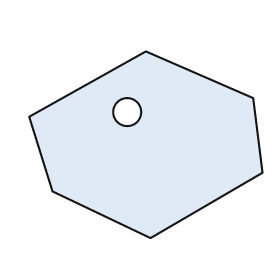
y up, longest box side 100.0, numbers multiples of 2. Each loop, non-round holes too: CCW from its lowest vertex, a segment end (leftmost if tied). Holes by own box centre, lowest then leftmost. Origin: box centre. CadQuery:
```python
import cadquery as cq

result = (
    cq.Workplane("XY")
    .moveTo(2.0, -40.0)
    .lineTo(50.0, -12.0)
    .lineTo(46.0, 20.0)
    .lineTo(0.0, 40.0)
    .lineTo(-50.0, 12.0)
    .lineTo(-40.0, -20.0)
    .close()
    .moveTo(-8.0, 14.0)
    .circle(6.0)
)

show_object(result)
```